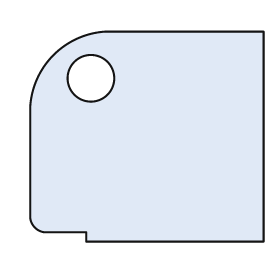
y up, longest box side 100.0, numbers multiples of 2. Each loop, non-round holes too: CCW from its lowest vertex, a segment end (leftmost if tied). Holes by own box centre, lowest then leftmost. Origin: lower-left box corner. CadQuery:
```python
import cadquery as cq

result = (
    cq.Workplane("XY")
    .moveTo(24.0, 0.0)
    .lineTo(100.0, 0.0)
    .lineTo(100.0, 90.0)
    .lineTo(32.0, 90.0)
    .threePointArc((10.0, 80.0), (0.0, 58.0))
    .lineTo(0.0, 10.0)
    .threePointArc((2.0, 6.0), (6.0, 4.0))
    .lineTo(24.0, 4.0)
    .close()
    .moveTo(26.0, 70.0)
    .circle(10.0)
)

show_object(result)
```